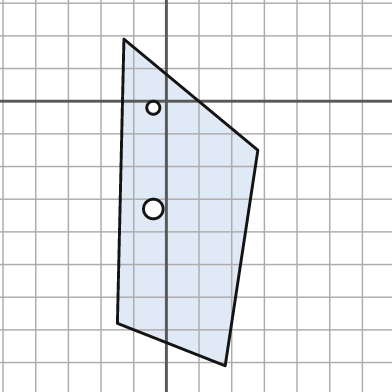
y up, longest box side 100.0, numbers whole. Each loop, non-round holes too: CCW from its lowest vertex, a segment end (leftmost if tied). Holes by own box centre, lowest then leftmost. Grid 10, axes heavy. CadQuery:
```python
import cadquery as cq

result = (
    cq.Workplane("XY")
    .moveTo(18.0, -81.0)
    .lineTo(28.0, -15.0)
    .lineTo(-13.0, 19.0)
    .lineTo(-15.0, -68.0)
    .close()
    .moveTo(-4.0, -33.0)
    .circle(3.0)
    .moveTo(-4.0, -2.0)
    .circle(2.0)
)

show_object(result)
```